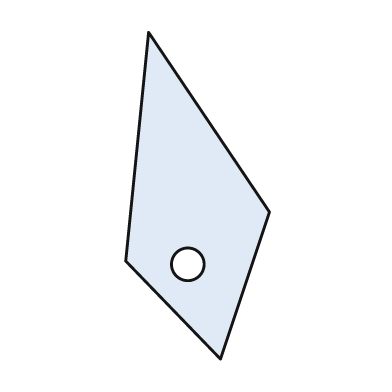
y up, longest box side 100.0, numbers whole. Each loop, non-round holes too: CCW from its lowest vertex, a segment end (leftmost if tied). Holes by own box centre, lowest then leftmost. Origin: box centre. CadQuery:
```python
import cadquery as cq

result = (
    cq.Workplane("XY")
    .moveTo(7.0, -50.0)
    .lineTo(22.0, -5.0)
    .lineTo(-15.0, 50.0)
    .lineTo(-22.0, -20.0)
    .close()
    .moveTo(-3.0, -21.0)
    .circle(5.0)
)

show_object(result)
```